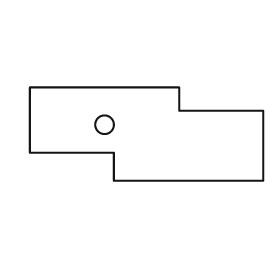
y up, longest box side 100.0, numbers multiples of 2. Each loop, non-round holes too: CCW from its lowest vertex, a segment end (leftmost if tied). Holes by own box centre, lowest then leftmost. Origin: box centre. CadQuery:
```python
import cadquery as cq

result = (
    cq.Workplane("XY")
    .moveTo(-14.0, -20.0)
    .lineTo(50.0, -20.0)
    .lineTo(50.0, 10.0)
    .lineTo(14.0, 10.0)
    .lineTo(14.0, 20.0)
    .lineTo(-50.0, 20.0)
    .lineTo(-50.0, -8.0)
    .lineTo(-14.0, -8.0)
    .close()
    .moveTo(-18.0, 4.0)
    .circle(4.0)
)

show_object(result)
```